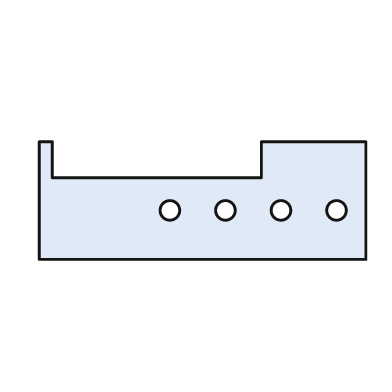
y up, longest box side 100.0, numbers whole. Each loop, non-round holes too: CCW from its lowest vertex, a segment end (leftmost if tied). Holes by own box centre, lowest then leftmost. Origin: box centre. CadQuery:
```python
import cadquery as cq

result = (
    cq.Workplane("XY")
    .moveTo(-50.0, -18.0)
    .lineTo(50.0, -18.0)
    .lineTo(50.0, 18.0)
    .lineTo(18.0, 18.0)
    .lineTo(18.0, 7.0)
    .lineTo(-46.0, 7.0)
    .lineTo(-46.0, 18.0)
    .lineTo(-50.0, 18.0)
    .close()
    .moveTo(-10.0, -3.0)
    .circle(3.0)
    .moveTo(7.0, -3.0)
    .circle(3.0)
    .moveTo(24.0, -3.0)
    .circle(3.0)
    .moveTo(41.0, -3.0)
    .circle(3.0)
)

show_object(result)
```